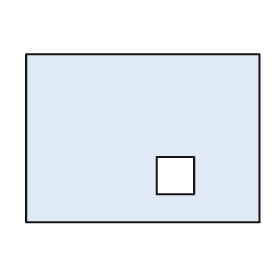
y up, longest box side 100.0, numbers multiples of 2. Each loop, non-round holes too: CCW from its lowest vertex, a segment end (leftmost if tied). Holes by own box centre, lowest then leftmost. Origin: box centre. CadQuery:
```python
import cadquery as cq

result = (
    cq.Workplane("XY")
    .moveTo(-50.0, -36.0)
    .lineTo(50.0, -36.0)
    .lineTo(50.0, 36.0)
    .lineTo(-50.0, 36.0)
    .close()
    .moveTo(6.0, -24.0)
    .lineTo(22.0, -24.0)
    .lineTo(22.0, -8.0)
    .lineTo(6.0, -8.0)
    .close()
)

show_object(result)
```